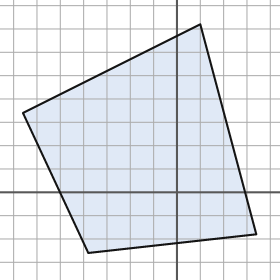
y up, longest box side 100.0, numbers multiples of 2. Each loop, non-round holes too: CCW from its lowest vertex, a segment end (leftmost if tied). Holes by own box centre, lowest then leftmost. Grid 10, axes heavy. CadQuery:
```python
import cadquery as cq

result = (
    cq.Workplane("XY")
    .moveTo(-38.0, -26.0)
    .lineTo(34.0, -18.0)
    .lineTo(10.0, 72.0)
    .lineTo(-66.0, 34.0)
    .close()
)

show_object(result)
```